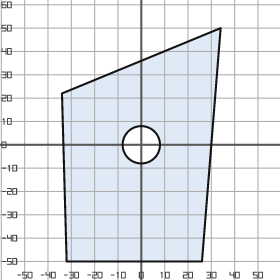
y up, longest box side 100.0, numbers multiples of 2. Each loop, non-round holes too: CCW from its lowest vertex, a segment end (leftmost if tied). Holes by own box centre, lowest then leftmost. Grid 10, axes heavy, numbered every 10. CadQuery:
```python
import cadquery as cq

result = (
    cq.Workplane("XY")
    .moveTo(-32.0, -50.0)
    .lineTo(26.0, -50.0)
    .lineTo(34.0, 50.0)
    .lineTo(-34.0, 22.0)
    .close()
    .moveTo(0.0, 0.0)
    .circle(8.0)
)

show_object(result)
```